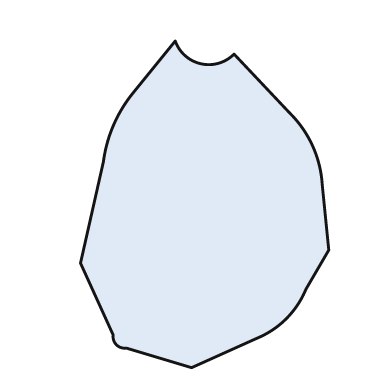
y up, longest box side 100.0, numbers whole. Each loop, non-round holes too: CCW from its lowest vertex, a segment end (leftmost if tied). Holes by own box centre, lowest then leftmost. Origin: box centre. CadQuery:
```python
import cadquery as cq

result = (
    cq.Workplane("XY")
    .moveTo(-4.0, -50.0)
    .lineTo(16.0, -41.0)
    .threePointArc((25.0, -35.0), (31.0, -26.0))
    .lineTo(38.0, -14.0)
    .lineTo(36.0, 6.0)
    .threePointArc((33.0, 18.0), (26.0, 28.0))
    .lineTo(9.0, 46.0)
    .threePointArc((-1.0, 43.0), (-9.0, 50.0))
    .lineTo(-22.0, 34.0)
    .threePointArc((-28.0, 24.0), (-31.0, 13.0))
    .lineTo(-38.0, -18.0)
    .lineTo(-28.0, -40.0)
    .threePointArc((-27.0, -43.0), (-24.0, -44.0))
    .close()
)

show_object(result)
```